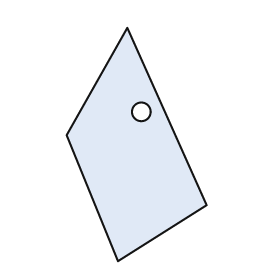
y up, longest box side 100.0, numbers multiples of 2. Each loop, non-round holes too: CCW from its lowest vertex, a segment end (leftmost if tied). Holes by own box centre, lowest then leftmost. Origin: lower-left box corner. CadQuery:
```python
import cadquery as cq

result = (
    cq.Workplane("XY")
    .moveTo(22.0, 0.0)
    .lineTo(60.0, 24.0)
    .lineTo(26.0, 100.0)
    .lineTo(0.0, 54.0)
    .close()
    .moveTo(32.0, 64.0)
    .circle(4.0)
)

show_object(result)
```